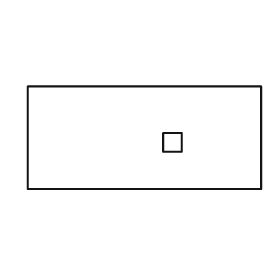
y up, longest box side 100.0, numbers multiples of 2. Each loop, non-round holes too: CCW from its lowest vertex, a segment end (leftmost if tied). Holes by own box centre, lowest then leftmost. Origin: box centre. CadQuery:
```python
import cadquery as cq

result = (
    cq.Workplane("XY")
    .moveTo(-50.0, -22.0)
    .lineTo(50.0, -22.0)
    .lineTo(50.0, 22.0)
    .lineTo(-50.0, 22.0)
    .close()
    .moveTo(8.0, -6.0)
    .lineTo(16.0, -6.0)
    .lineTo(16.0, 2.0)
    .lineTo(8.0, 2.0)
    .close()
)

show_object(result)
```